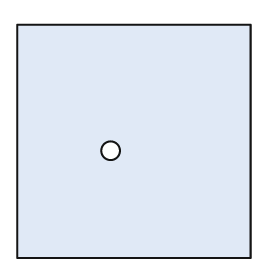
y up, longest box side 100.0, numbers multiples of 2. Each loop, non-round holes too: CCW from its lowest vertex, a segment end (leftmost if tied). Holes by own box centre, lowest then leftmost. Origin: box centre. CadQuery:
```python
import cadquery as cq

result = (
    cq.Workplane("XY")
    .moveTo(-50.0, -50.0)
    .lineTo(50.0, -50.0)
    .lineTo(50.0, 50.0)
    .lineTo(-50.0, 50.0)
    .close()
    .moveTo(-10.0, -4.0)
    .circle(4.0)
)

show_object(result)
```